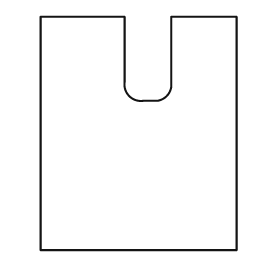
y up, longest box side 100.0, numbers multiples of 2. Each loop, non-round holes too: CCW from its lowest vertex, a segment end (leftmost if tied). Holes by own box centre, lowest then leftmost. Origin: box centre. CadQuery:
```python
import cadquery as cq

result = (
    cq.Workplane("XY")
    .moveTo(-42.0, -50.0)
    .lineTo(42.0, -50.0)
    .lineTo(42.0, 50.0)
    .lineTo(14.0, 50.0)
    .lineTo(14.0, 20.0)
    .threePointArc((12.0, 16.0), (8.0, 14.0))
    .lineTo(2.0, 14.0)
    .threePointArc((-4.0, 16.0), (-6.0, 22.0))
    .lineTo(-6.0, 50.0)
    .lineTo(-42.0, 50.0)
    .close()
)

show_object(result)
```